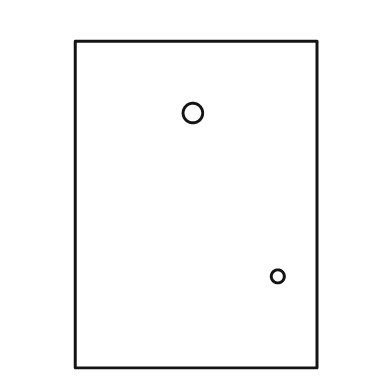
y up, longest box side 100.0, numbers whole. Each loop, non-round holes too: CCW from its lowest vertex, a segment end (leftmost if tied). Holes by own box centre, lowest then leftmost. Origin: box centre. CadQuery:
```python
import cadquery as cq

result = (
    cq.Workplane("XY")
    .moveTo(-37.0, -50.0)
    .lineTo(37.0, -50.0)
    .lineTo(37.0, 50.0)
    .lineTo(-37.0, 50.0)
    .close()
    .moveTo(25.0, -22.0)
    .circle(2.0)
    .moveTo(-1.0, 28.0)
    .circle(3.0)
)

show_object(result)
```